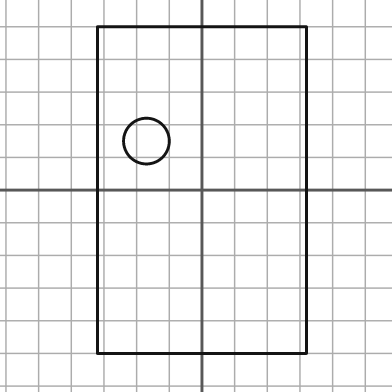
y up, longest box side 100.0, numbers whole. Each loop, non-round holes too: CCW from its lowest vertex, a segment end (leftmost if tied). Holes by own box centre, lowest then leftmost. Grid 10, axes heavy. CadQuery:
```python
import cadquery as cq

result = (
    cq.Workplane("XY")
    .moveTo(-32.0, -50.0)
    .lineTo(32.0, -50.0)
    .lineTo(32.0, 50.0)
    .lineTo(-32.0, 50.0)
    .close()
    .moveTo(-17.0, 15.0)
    .circle(7.0)
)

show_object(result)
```